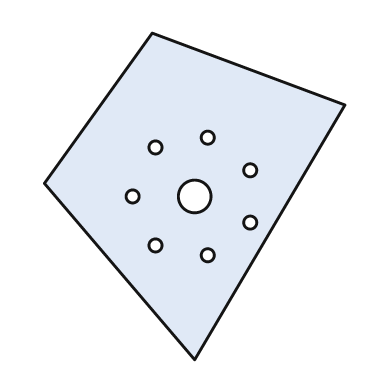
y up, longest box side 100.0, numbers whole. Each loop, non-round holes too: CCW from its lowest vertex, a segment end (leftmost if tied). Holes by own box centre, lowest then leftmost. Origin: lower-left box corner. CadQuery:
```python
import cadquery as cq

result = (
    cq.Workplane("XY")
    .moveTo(46.0, 0.0)
    .lineTo(92.0, 78.0)
    .lineTo(33.0, 100.0)
    .lineTo(0.0, 54.0)
    .close()
    .moveTo(50.0, 32.0)
    .circle(2.0)
    .moveTo(34.0, 35.0)
    .circle(2.0)
    .moveTo(63.0, 42.0)
    .circle(2.0)
    .moveTo(27.0, 50.0)
    .circle(2.0)
    .moveTo(46.0, 50.0)
    .circle(5.0)
    .moveTo(63.0, 58.0)
    .circle(2.0)
    .moveTo(34.0, 65.0)
    .circle(2.0)
    .moveTo(50.0, 68.0)
    .circle(2.0)
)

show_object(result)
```